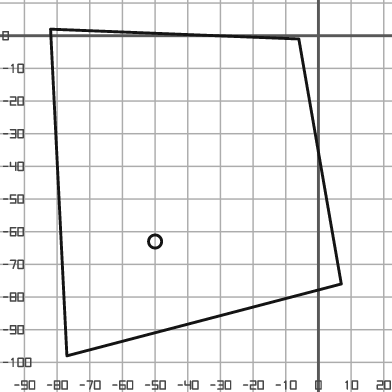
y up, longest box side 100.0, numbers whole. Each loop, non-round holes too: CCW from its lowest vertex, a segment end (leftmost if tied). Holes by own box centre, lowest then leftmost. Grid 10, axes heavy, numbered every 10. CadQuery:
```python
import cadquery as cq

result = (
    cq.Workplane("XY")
    .moveTo(-77.0, -98.0)
    .lineTo(7.0, -76.0)
    .lineTo(-6.0, -1.0)
    .lineTo(-82.0, 2.0)
    .close()
    .moveTo(-50.0, -63.0)
    .circle(2.0)
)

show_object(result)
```